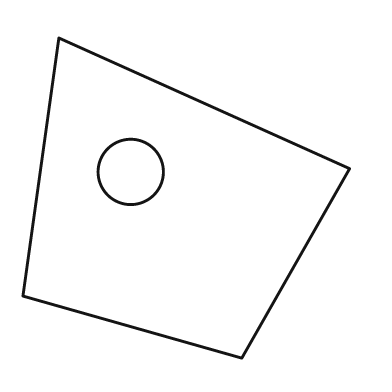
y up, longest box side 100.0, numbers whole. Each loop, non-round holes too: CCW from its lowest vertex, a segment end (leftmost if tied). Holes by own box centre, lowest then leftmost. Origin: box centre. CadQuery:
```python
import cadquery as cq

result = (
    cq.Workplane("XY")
    .moveTo(17.0, -49.0)
    .lineTo(50.0, 9.0)
    .lineTo(-39.0, 49.0)
    .lineTo(-50.0, -30.0)
    .close()
    .moveTo(-17.0, 8.0)
    .circle(10.0)
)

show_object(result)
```